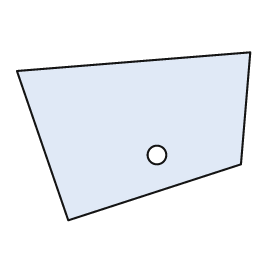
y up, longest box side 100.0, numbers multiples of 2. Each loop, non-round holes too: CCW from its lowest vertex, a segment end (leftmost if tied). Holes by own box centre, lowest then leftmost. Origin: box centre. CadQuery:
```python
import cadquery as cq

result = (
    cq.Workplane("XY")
    .moveTo(-28.0, -36.0)
    .lineTo(46.0, -12.0)
    .lineTo(50.0, 36.0)
    .lineTo(-50.0, 28.0)
    .close()
    .moveTo(10.0, -8.0)
    .circle(4.0)
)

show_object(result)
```